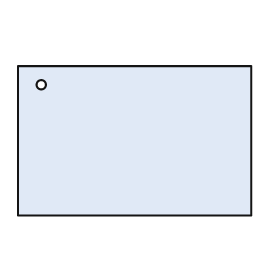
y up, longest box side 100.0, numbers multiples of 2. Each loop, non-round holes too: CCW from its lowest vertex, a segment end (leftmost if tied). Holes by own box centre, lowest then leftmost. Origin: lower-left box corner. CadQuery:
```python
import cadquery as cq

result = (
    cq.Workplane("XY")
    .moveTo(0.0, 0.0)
    .lineTo(100.0, 0.0)
    .lineTo(100.0, 64.0)
    .lineTo(0.0, 64.0)
    .close()
    .moveTo(10.0, 56.0)
    .circle(2.0)
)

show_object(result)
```